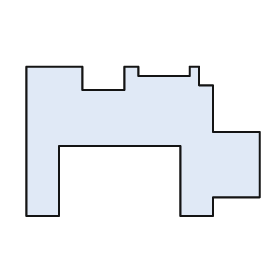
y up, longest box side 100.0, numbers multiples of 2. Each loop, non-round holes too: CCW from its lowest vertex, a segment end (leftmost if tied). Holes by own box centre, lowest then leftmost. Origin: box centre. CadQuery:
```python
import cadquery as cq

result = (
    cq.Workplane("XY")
    .moveTo(-50.0, -32.0)
    .lineTo(-36.0, -32.0)
    .lineTo(-36.0, -2.0)
    .lineTo(16.0, -2.0)
    .lineTo(16.0, -32.0)
    .lineTo(30.0, -32.0)
    .lineTo(30.0, -24.0)
    .lineTo(50.0, -24.0)
    .lineTo(50.0, 4.0)
    .lineTo(30.0, 4.0)
    .lineTo(30.0, 24.0)
    .lineTo(24.0, 24.0)
    .lineTo(24.0, 32.0)
    .lineTo(20.0, 32.0)
    .lineTo(20.0, 28.0)
    .lineTo(-2.0, 28.0)
    .lineTo(-2.0, 32.0)
    .lineTo(-8.0, 32.0)
    .lineTo(-8.0, 22.0)
    .lineTo(-26.0, 22.0)
    .lineTo(-26.0, 32.0)
    .lineTo(-50.0, 32.0)
    .close()
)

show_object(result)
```